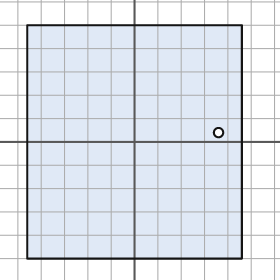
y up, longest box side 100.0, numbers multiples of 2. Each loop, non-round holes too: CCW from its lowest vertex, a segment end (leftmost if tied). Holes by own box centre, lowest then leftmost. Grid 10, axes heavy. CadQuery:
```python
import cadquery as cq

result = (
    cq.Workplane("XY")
    .moveTo(-46.0, -50.0)
    .lineTo(46.0, -50.0)
    .lineTo(46.0, 50.0)
    .lineTo(-46.0, 50.0)
    .close()
    .moveTo(36.0, 4.0)
    .circle(2.0)
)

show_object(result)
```